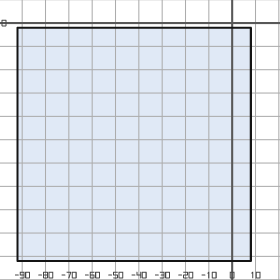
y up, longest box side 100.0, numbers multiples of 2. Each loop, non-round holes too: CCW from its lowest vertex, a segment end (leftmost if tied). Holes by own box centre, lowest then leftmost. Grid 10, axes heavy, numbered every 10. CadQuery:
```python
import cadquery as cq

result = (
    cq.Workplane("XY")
    .moveTo(-92.0, -102.0)
    .lineTo(8.0, -102.0)
    .lineTo(8.0, -2.0)
    .lineTo(-92.0, -2.0)
    .close()
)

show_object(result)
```